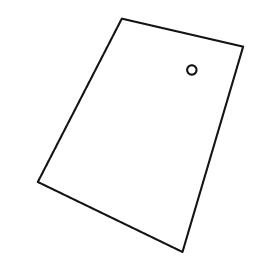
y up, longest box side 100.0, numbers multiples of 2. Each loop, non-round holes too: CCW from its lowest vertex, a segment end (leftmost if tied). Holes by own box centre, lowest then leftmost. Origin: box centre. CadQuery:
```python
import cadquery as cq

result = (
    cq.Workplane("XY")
    .moveTo(18.0, -50.0)
    .lineTo(44.0, 38.0)
    .lineTo(-8.0, 50.0)
    .lineTo(-44.0, -20.0)
    .close()
    .moveTo(22.0, 28.0)
    .circle(2.0)
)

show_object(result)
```